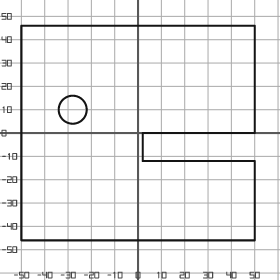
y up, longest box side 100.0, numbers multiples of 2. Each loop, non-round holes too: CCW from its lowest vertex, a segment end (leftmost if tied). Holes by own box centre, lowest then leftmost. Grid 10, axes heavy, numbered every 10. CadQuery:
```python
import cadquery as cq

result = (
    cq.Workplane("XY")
    .moveTo(-50.0, -46.0)
    .lineTo(50.0, -46.0)
    .lineTo(50.0, -12.0)
    .lineTo(2.0, -12.0)
    .lineTo(2.0, 0.0)
    .lineTo(50.0, 0.0)
    .lineTo(50.0, 46.0)
    .lineTo(-50.0, 46.0)
    .close()
    .moveTo(-28.0, 10.0)
    .circle(6.0)
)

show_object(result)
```